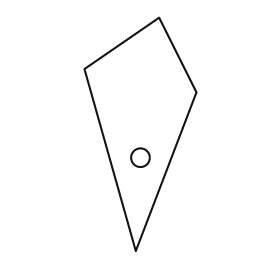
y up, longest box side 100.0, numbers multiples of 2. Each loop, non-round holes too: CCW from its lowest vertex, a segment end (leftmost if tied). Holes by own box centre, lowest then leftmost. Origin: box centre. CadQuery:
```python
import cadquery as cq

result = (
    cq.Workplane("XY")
    .moveTo(-2.0, -50.0)
    .lineTo(24.0, 18.0)
    .lineTo(8.0, 50.0)
    .lineTo(-24.0, 28.0)
    .close()
    .moveTo(0.0, -10.0)
    .circle(4.0)
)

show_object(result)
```